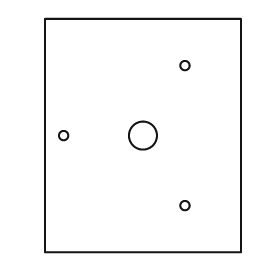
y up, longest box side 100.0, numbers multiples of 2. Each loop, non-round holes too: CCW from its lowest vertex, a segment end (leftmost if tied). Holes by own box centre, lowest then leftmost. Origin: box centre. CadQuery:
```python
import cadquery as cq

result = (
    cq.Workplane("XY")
    .moveTo(-42.0, -50.0)
    .lineTo(42.0, -50.0)
    .lineTo(42.0, 50.0)
    .lineTo(-42.0, 50.0)
    .close()
    .moveTo(18.0, -30.0)
    .circle(2.0)
    .moveTo(-34.0, 0.0)
    .circle(2.0)
    .moveTo(0.0, 0.0)
    .circle(6.0)
    .moveTo(18.0, 30.0)
    .circle(2.0)
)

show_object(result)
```